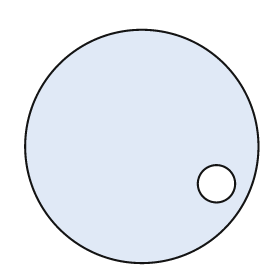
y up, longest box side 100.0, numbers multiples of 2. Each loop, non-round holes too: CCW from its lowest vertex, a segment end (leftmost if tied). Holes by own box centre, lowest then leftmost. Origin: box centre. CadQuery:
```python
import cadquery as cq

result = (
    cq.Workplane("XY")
    .moveTo(0.0, 0.0)
    .circle(50.0)
    .moveTo(32.0, -16.0)
    .circle(8.0)
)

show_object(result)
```